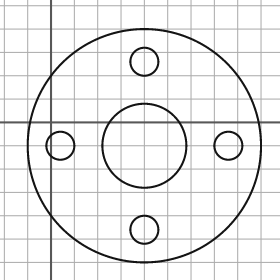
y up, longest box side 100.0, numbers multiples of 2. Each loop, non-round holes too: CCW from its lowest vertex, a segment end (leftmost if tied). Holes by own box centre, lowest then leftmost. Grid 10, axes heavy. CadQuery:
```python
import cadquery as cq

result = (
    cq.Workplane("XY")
    .moveTo(40.0, -10.0)
    .circle(50.0)
    .moveTo(40.0, -46.0)
    .circle(6.0)
    .moveTo(4.0, -10.0)
    .circle(6.0)
    .moveTo(40.0, -10.0)
    .circle(18.0)
    .moveTo(76.0, -10.0)
    .circle(6.0)
    .moveTo(40.0, 26.0)
    .circle(6.0)
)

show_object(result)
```